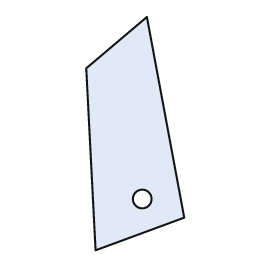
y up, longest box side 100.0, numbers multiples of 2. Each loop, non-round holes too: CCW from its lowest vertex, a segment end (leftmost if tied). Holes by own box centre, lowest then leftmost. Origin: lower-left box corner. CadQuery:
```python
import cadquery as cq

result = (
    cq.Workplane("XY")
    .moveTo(4.0, 0.0)
    .lineTo(42.0, 14.0)
    .lineTo(26.0, 100.0)
    .lineTo(0.0, 78.0)
    .close()
    .moveTo(24.0, 22.0)
    .circle(4.0)
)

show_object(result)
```